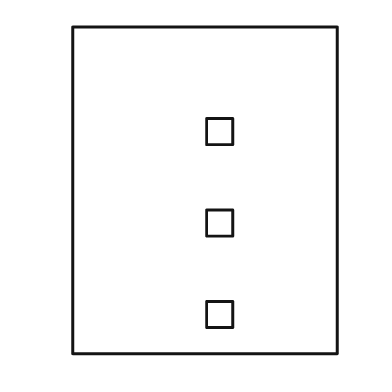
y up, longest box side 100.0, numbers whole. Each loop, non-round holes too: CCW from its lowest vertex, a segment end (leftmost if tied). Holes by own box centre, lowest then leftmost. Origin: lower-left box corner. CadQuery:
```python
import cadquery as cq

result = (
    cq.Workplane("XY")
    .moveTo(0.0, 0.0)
    .lineTo(81.0, 0.0)
    .lineTo(81.0, 100.0)
    .lineTo(0.0, 100.0)
    .close()
    .moveTo(41.0, 8.0)
    .lineTo(49.0, 8.0)
    .lineTo(49.0, 16.0)
    .lineTo(41.0, 16.0)
    .close()
    .moveTo(41.0, 36.0)
    .lineTo(49.0, 36.0)
    .lineTo(49.0, 44.0)
    .lineTo(41.0, 44.0)
    .close()
    .moveTo(41.0, 64.0)
    .lineTo(49.0, 64.0)
    .lineTo(49.0, 72.0)
    .lineTo(41.0, 72.0)
    .close()
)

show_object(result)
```